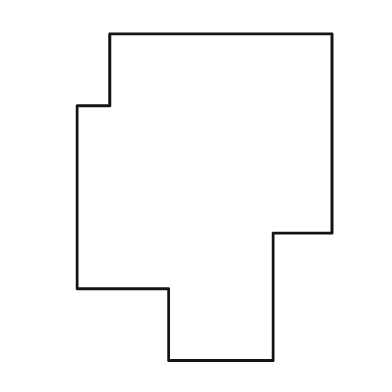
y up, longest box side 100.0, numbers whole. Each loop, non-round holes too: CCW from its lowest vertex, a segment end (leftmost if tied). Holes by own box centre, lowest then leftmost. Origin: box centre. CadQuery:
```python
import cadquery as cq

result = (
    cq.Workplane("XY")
    .moveTo(-11.0, -50.0)
    .lineTo(21.0, -50.0)
    .lineTo(21.0, -11.0)
    .lineTo(39.0, -11.0)
    .lineTo(39.0, 50.0)
    .lineTo(-29.0, 50.0)
    .lineTo(-29.0, 28.0)
    .lineTo(-39.0, 28.0)
    .lineTo(-39.0, -28.0)
    .lineTo(-11.0, -28.0)
    .close()
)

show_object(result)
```